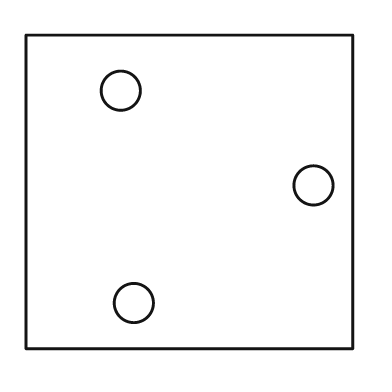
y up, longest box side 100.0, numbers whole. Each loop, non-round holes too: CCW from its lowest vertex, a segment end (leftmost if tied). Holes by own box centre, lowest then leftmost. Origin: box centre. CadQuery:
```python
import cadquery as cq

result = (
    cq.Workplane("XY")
    .moveTo(-50.0, -48.0)
    .lineTo(50.0, -48.0)
    .lineTo(50.0, 48.0)
    .lineTo(-50.0, 48.0)
    .close()
    .moveTo(-17.0, -34.0)
    .circle(6.0)
    .moveTo(38.0, 2.0)
    .circle(6.0)
    .moveTo(-21.0, 31.0)
    .circle(6.0)
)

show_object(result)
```